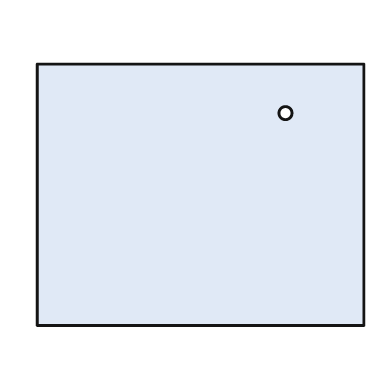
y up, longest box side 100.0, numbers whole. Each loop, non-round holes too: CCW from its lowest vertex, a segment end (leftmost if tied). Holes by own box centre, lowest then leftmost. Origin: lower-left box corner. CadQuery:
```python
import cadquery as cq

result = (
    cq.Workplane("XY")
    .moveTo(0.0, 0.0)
    .lineTo(100.0, 0.0)
    .lineTo(100.0, 80.0)
    .lineTo(0.0, 80.0)
    .close()
    .moveTo(76.0, 65.0)
    .circle(2.0)
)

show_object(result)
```